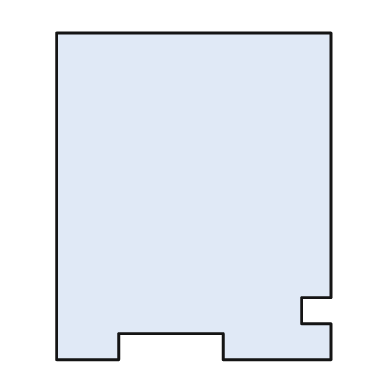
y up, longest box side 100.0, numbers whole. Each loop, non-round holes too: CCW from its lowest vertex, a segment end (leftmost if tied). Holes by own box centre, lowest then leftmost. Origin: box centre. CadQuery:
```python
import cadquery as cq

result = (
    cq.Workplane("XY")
    .moveTo(-42.0, -50.0)
    .lineTo(-23.0, -50.0)
    .lineTo(-23.0, -42.0)
    .lineTo(9.0, -42.0)
    .lineTo(9.0, -50.0)
    .lineTo(42.0, -50.0)
    .lineTo(42.0, -39.0)
    .lineTo(33.0, -39.0)
    .lineTo(33.0, -31.0)
    .lineTo(42.0, -31.0)
    .lineTo(42.0, 50.0)
    .lineTo(-42.0, 50.0)
    .close()
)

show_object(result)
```